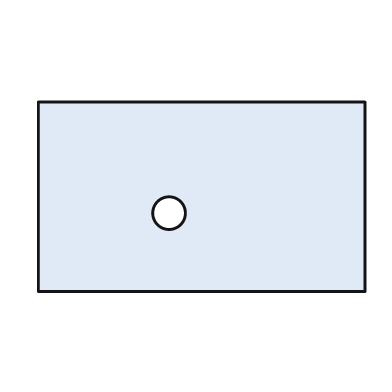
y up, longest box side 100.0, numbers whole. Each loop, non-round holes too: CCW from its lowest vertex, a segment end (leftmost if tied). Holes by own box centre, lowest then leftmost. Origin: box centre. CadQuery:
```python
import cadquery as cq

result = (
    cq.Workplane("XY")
    .moveTo(-50.0, -29.0)
    .lineTo(50.0, -29.0)
    .lineTo(50.0, 29.0)
    .lineTo(-50.0, 29.0)
    .close()
    .moveTo(-10.0, -5.0)
    .circle(5.0)
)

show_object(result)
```